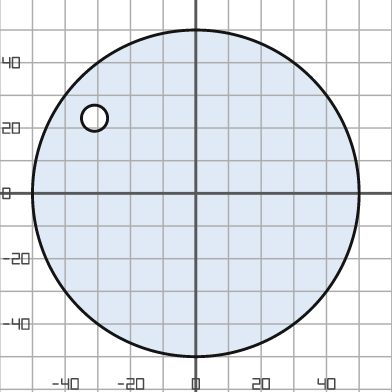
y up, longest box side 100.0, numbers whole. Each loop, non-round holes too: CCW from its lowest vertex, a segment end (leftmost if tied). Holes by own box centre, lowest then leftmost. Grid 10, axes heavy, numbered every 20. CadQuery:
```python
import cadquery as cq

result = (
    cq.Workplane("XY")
    .moveTo(0.0, 0.0)
    .circle(50.0)
    .moveTo(-31.0, 23.0)
    .circle(4.0)
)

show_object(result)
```